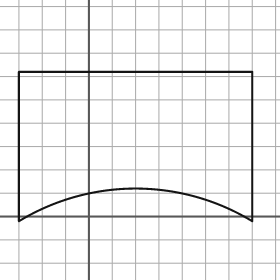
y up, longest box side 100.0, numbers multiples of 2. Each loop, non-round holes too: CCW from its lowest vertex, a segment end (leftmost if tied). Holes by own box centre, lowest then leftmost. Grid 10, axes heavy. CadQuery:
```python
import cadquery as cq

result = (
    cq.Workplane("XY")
    .moveTo(-30.0, -2.0)
    .threePointArc((20.0, 12.0), (70.0, -2.0))
    .lineTo(70.0, 62.0)
    .lineTo(-30.0, 62.0)
    .close()
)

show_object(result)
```